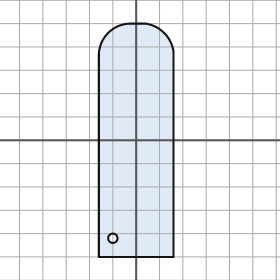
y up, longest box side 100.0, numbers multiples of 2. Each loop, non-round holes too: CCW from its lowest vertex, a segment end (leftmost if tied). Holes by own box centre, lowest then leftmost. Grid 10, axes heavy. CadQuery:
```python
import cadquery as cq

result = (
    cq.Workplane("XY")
    .moveTo(-16.0, -50.0)
    .lineTo(16.0, -50.0)
    .lineTo(16.0, 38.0)
    .threePointArc((12.0, 46.0), (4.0, 50.0))
    .lineTo(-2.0, 50.0)
    .threePointArc((-12.0, 46.0), (-16.0, 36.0))
    .close()
    .moveTo(-10.0, -42.0)
    .circle(2.0)
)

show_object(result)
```